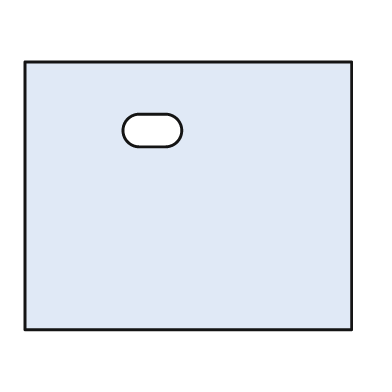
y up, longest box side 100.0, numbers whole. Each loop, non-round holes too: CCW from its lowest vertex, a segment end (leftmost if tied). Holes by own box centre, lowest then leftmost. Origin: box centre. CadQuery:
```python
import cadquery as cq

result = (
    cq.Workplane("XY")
    .moveTo(-50.0, -41.0)
    .lineTo(50.0, -41.0)
    .lineTo(50.0, 41.0)
    .lineTo(-50.0, 41.0)
    .close()
    .moveTo(-15.0, 15.0)
    .lineTo(-7.0, 15.0)
    .threePointArc((-2.0, 20.0), (-7.0, 25.0))
    .lineTo(-15.0, 25.0)
    .threePointArc((-20.0, 20.0), (-15.0, 15.0))
    .close()
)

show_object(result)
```